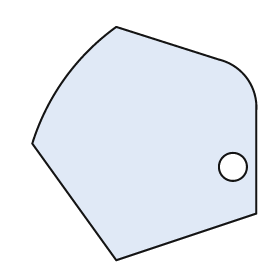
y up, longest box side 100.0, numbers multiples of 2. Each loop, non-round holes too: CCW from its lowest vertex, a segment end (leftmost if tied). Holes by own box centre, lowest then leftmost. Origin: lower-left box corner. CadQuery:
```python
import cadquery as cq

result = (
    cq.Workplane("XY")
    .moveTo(36.0, 0.0)
    .lineTo(96.0, 20.0)
    .lineTo(96.0, 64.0)
    .threePointArc((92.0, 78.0), (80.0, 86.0))
    .lineTo(36.0, 100.0)
    .threePointArc((14.0, 78.0), (0.0, 50.0))
    .close()
    .moveTo(86.0, 40.0)
    .circle(6.0)
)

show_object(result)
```